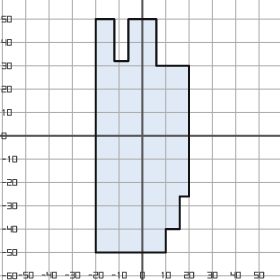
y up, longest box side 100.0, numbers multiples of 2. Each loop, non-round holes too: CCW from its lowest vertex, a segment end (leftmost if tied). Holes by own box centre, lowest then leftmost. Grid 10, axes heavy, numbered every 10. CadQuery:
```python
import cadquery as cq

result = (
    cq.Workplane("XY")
    .moveTo(-20.0, -50.0)
    .lineTo(10.0, -50.0)
    .lineTo(10.0, -40.0)
    .lineTo(16.0, -40.0)
    .lineTo(16.0, -26.0)
    .lineTo(20.0, -26.0)
    .lineTo(20.0, 30.0)
    .lineTo(6.0, 30.0)
    .lineTo(6.0, 50.0)
    .lineTo(-6.0, 50.0)
    .lineTo(-6.0, 32.0)
    .lineTo(-12.0, 32.0)
    .lineTo(-12.0, 50.0)
    .lineTo(-20.0, 50.0)
    .close()
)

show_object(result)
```